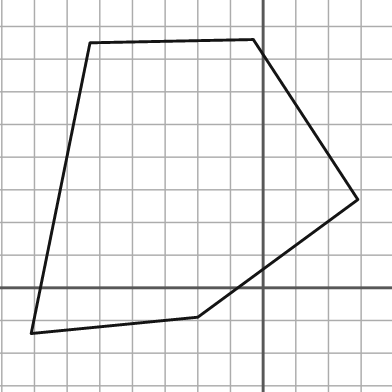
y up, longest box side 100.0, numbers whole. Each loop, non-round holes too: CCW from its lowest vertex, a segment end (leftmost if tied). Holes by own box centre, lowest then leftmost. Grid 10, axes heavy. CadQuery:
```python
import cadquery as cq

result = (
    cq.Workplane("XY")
    .moveTo(-71.0, -14.0)
    .lineTo(-20.0, -9.0)
    .lineTo(29.0, 27.0)
    .lineTo(-3.0, 76.0)
    .lineTo(-53.0, 75.0)
    .close()
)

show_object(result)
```